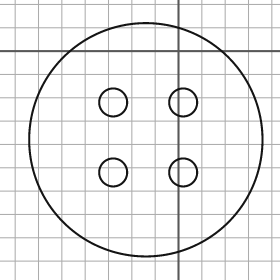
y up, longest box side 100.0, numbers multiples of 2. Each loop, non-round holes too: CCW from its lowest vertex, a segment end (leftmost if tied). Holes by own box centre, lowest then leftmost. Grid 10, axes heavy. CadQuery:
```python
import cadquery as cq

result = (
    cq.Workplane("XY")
    .moveTo(-14.0, -38.0)
    .circle(50.0)
    .moveTo(-28.0, -52.0)
    .circle(6.0)
    .moveTo(2.0, -52.0)
    .circle(6.0)
    .moveTo(-28.0, -22.0)
    .circle(6.0)
    .moveTo(2.0, -22.0)
    .circle(6.0)
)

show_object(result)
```